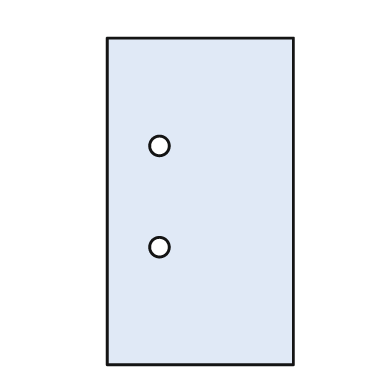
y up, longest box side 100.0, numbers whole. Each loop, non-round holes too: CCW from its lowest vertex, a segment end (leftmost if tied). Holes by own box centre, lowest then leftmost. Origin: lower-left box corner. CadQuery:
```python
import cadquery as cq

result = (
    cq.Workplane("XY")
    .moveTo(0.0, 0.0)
    .lineTo(57.0, 0.0)
    .lineTo(57.0, 100.0)
    .lineTo(0.0, 100.0)
    .close()
    .moveTo(16.0, 36.0)
    .circle(3.0)
    .moveTo(16.0, 67.0)
    .circle(3.0)
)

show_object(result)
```